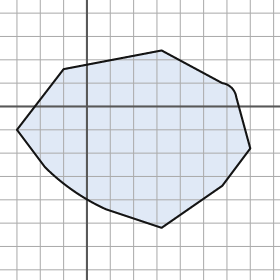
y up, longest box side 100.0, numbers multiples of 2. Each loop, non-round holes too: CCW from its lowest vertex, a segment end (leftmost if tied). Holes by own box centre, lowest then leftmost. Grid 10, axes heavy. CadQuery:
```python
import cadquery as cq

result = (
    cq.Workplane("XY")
    .moveTo(32.0, -52.0)
    .lineTo(58.0, -34.0)
    .lineTo(70.0, -18.0)
    .lineTo(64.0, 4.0)
    .threePointArc((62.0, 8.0), (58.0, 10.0))
    .lineTo(32.0, 24.0)
    .lineTo(-10.0, 16.0)
    .lineTo(-30.0, -10.0)
    .lineTo(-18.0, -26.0)
    .threePointArc((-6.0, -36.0), (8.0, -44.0))
    .close()
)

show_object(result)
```